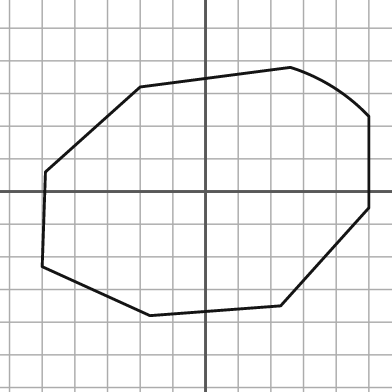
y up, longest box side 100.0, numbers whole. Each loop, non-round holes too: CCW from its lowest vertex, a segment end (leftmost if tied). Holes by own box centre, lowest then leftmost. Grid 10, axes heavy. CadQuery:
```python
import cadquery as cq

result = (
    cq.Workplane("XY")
    .moveTo(-17.0, -38.0)
    .lineTo(23.0, -35.0)
    .lineTo(50.0, -5.0)
    .lineTo(50.0, 23.0)
    .threePointArc((39.0, 32.0), (26.0, 38.0))
    .lineTo(-20.0, 32.0)
    .lineTo(-49.0, 6.0)
    .lineTo(-50.0, -23.0)
    .close()
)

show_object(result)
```